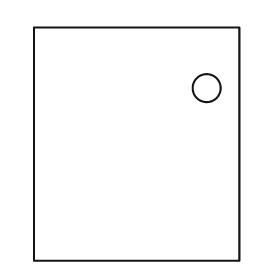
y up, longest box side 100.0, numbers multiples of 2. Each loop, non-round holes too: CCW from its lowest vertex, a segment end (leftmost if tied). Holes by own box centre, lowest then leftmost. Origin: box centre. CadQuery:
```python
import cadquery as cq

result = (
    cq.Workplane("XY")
    .moveTo(-44.0, -50.0)
    .lineTo(44.0, -50.0)
    .lineTo(44.0, 50.0)
    .lineTo(-44.0, 50.0)
    .close()
    .moveTo(30.0, 24.0)
    .circle(6.0)
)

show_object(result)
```